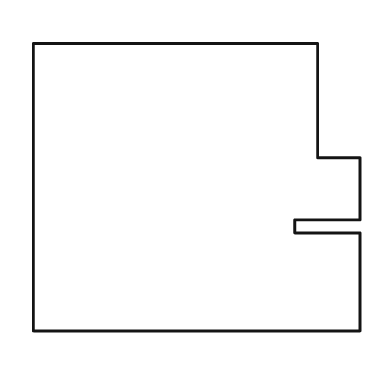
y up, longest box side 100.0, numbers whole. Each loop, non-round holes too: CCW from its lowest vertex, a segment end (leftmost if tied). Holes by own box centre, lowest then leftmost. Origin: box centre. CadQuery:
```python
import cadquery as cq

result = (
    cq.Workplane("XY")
    .moveTo(-50.0, -44.0)
    .lineTo(50.0, -44.0)
    .lineTo(50.0, -14.0)
    .lineTo(30.0, -14.0)
    .lineTo(30.0, -10.0)
    .lineTo(50.0, -10.0)
    .lineTo(50.0, 9.0)
    .lineTo(37.0, 9.0)
    .lineTo(37.0, 44.0)
    .lineTo(-50.0, 44.0)
    .close()
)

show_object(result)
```